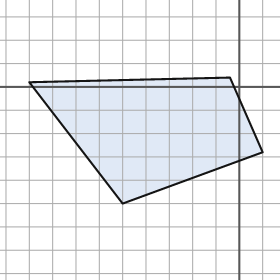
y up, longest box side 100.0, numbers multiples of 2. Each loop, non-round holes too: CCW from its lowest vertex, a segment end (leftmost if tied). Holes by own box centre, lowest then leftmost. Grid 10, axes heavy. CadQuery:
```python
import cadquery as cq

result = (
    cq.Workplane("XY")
    .moveTo(-50.0, -50.0)
    .lineTo(10.0, -28.0)
    .lineTo(-4.0, 4.0)
    .lineTo(-90.0, 2.0)
    .close()
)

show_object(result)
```